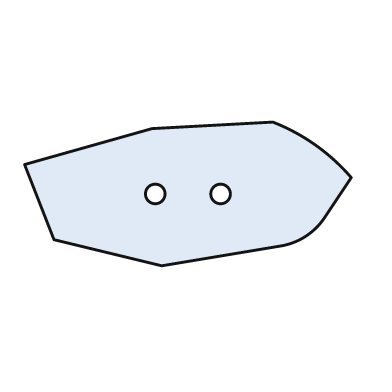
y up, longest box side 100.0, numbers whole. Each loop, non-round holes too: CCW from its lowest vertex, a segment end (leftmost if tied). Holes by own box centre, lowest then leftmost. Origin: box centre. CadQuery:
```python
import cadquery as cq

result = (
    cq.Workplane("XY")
    .moveTo(-8.0, -22.0)
    .lineTo(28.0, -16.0)
    .threePointArc((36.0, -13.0), (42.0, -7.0))
    .lineTo(50.0, 5.0)
    .threePointArc((39.0, 15.0), (26.0, 22.0))
    .lineTo(-11.0, 20.0)
    .lineTo(-50.0, 9.0)
    .lineTo(-41.0, -14.0)
    .close()
    .moveTo(-10.0, 0.0)
    .circle(3.0)
    .moveTo(10.0, 0.0)
    .circle(3.0)
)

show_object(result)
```